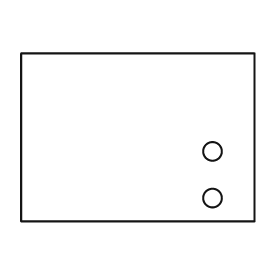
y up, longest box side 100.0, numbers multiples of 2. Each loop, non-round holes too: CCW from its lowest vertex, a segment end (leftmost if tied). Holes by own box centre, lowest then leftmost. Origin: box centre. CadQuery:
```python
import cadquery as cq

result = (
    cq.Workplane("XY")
    .moveTo(-50.0, -36.0)
    .lineTo(50.0, -36.0)
    .lineTo(50.0, 36.0)
    .lineTo(-50.0, 36.0)
    .close()
    .moveTo(32.0, -26.0)
    .circle(4.0)
    .moveTo(32.0, -6.0)
    .circle(4.0)
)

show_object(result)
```